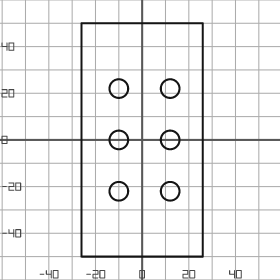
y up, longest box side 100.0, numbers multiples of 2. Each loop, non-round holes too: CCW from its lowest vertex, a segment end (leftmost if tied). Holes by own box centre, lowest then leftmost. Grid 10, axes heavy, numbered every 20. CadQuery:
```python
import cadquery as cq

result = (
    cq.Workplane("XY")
    .moveTo(-26.0, -50.0)
    .lineTo(26.0, -50.0)
    .lineTo(26.0, 50.0)
    .lineTo(-26.0, 50.0)
    .close()
    .moveTo(-10.0, -22.0)
    .circle(4.0)
    .moveTo(12.0, -22.0)
    .circle(4.0)
    .moveTo(-10.0, 0.0)
    .circle(4.0)
    .moveTo(12.0, 0.0)
    .circle(4.0)
    .moveTo(-10.0, 22.0)
    .circle(4.0)
    .moveTo(12.0, 22.0)
    .circle(4.0)
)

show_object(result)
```